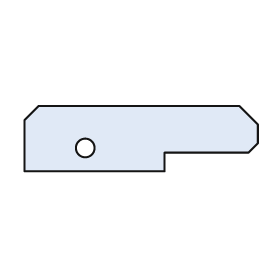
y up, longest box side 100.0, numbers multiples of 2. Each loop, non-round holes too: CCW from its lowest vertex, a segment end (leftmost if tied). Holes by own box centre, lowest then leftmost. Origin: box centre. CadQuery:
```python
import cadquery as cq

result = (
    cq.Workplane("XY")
    .moveTo(-50.0, -14.0)
    .lineTo(10.0, -14.0)
    .lineTo(10.0, -6.0)
    .lineTo(46.0, -6.0)
    .lineTo(50.0, -2.0)
    .lineTo(50.0, 6.0)
    .lineTo(42.0, 14.0)
    .lineTo(-44.0, 14.0)
    .lineTo(-50.0, 8.0)
    .close()
    .moveTo(-24.0, -4.0)
    .circle(4.0)
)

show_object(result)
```